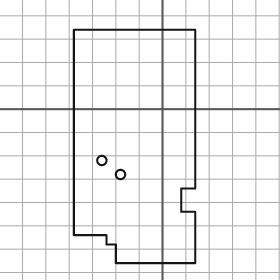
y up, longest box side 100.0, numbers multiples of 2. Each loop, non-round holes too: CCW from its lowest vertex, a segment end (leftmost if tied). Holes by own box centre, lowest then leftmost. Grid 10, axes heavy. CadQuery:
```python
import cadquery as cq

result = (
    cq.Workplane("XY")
    .moveTo(-20.0, -66.0)
    .lineTo(14.0, -66.0)
    .lineTo(14.0, -44.0)
    .lineTo(8.0, -44.0)
    .lineTo(8.0, -34.0)
    .lineTo(14.0, -34.0)
    .lineTo(14.0, 34.0)
    .lineTo(-38.0, 34.0)
    .lineTo(-38.0, -54.0)
    .lineTo(-24.0, -54.0)
    .lineTo(-24.0, -58.0)
    .lineTo(-20.0, -58.0)
    .close()
    .moveTo(-18.0, -28.0)
    .circle(2.0)
    .moveTo(-26.0, -22.0)
    .circle(2.0)
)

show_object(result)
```